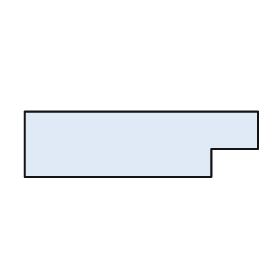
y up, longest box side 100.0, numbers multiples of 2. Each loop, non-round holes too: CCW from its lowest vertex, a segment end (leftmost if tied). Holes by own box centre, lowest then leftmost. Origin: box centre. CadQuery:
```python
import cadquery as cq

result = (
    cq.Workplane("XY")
    .moveTo(-50.0, -14.0)
    .lineTo(30.0, -14.0)
    .lineTo(30.0, -2.0)
    .lineTo(50.0, -2.0)
    .lineTo(50.0, 14.0)
    .lineTo(-50.0, 14.0)
    .close()
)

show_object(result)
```